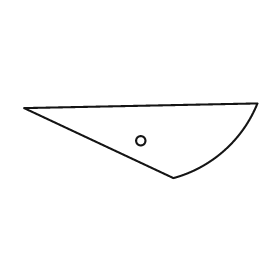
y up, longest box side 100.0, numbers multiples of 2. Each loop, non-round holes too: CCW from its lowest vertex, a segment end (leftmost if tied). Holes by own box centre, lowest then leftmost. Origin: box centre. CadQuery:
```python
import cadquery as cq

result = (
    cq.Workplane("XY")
    .moveTo(14.0, -16.0)
    .threePointArc((36.0, -4.0), (50.0, 16.0))
    .lineTo(-50.0, 14.0)
    .close()
    .moveTo(0.0, 0.0)
    .circle(2.0)
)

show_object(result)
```